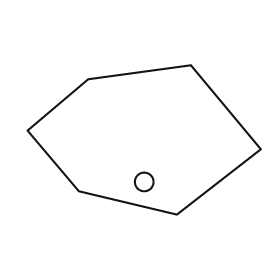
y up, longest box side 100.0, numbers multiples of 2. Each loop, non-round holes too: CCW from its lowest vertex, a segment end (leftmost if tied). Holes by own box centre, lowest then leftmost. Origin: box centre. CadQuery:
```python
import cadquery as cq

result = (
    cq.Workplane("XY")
    .moveTo(14.0, -32.0)
    .lineTo(50.0, -4.0)
    .lineTo(20.0, 32.0)
    .lineTo(-24.0, 26.0)
    .lineTo(-50.0, 4.0)
    .lineTo(-28.0, -22.0)
    .close()
    .moveTo(0.0, -18.0)
    .circle(4.0)
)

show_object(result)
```